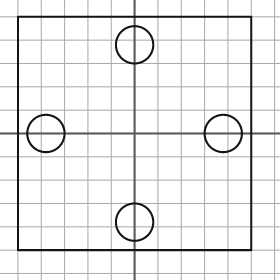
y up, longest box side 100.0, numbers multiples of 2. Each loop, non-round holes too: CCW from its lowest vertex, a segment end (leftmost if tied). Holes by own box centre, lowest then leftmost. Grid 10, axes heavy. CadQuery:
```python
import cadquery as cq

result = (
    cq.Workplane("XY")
    .moveTo(-50.0, -50.0)
    .lineTo(50.0, -50.0)
    .lineTo(50.0, 50.0)
    .lineTo(-50.0, 50.0)
    .close()
    .moveTo(0.0, -38.0)
    .circle(8.0)
    .moveTo(-38.0, 0.0)
    .circle(8.0)
    .moveTo(38.0, 0.0)
    .circle(8.0)
    .moveTo(0.0, 38.0)
    .circle(8.0)
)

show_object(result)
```